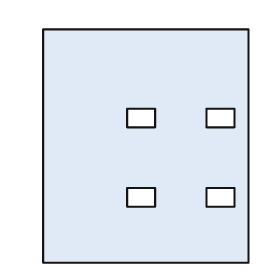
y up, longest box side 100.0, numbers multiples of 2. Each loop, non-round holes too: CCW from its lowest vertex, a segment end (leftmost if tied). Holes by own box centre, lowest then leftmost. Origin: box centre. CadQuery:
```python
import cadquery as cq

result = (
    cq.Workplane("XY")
    .moveTo(-44.0, -50.0)
    .lineTo(44.0, -50.0)
    .lineTo(44.0, 50.0)
    .lineTo(-44.0, 50.0)
    .close()
    .moveTo(-8.0, -26.0)
    .lineTo(4.0, -26.0)
    .lineTo(4.0, -18.0)
    .lineTo(-8.0, -18.0)
    .close()
    .moveTo(26.0, -26.0)
    .lineTo(38.0, -26.0)
    .lineTo(38.0, -18.0)
    .lineTo(26.0, -18.0)
    .close()
    .moveTo(-8.0, 8.0)
    .lineTo(4.0, 8.0)
    .lineTo(4.0, 16.0)
    .lineTo(-8.0, 16.0)
    .close()
    .moveTo(26.0, 8.0)
    .lineTo(38.0, 8.0)
    .lineTo(38.0, 16.0)
    .lineTo(26.0, 16.0)
    .close()
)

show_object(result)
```